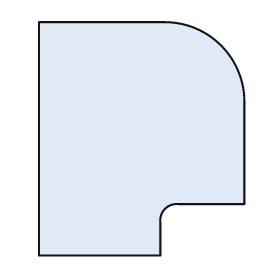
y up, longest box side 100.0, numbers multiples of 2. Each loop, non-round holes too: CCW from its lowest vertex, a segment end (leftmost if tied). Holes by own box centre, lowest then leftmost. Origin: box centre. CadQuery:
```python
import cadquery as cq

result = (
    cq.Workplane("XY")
    .moveTo(-44.0, -50.0)
    .lineTo(8.0, -50.0)
    .lineTo(8.0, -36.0)
    .threePointArc((10.0, -30.0), (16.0, -28.0))
    .lineTo(44.0, -28.0)
    .lineTo(44.0, 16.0)
    .threePointArc((34.0, 40.0), (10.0, 50.0))
    .lineTo(-44.0, 50.0)
    .close()
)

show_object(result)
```